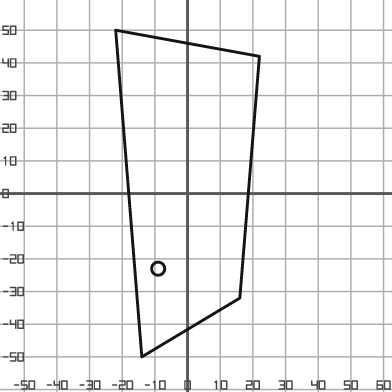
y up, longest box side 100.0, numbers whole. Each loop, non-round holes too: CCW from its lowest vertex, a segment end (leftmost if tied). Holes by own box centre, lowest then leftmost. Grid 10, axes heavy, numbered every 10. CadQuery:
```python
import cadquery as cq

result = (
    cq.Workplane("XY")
    .moveTo(-14.0, -50.0)
    .lineTo(16.0, -32.0)
    .lineTo(22.0, 42.0)
    .lineTo(-22.0, 50.0)
    .close()
    .moveTo(-9.0, -23.0)
    .circle(2.0)
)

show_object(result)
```